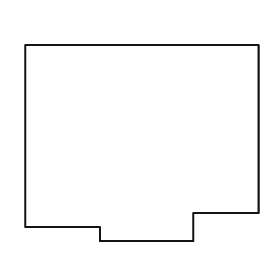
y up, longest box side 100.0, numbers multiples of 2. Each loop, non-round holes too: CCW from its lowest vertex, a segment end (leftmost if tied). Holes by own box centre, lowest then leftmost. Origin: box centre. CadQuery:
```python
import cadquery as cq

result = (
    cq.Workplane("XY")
    .moveTo(-18.0, -42.0)
    .lineTo(22.0, -42.0)
    .lineTo(22.0, -30.0)
    .lineTo(50.0, -30.0)
    .lineTo(50.0, 42.0)
    .lineTo(-50.0, 42.0)
    .lineTo(-50.0, -36.0)
    .lineTo(-18.0, -36.0)
    .close()
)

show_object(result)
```